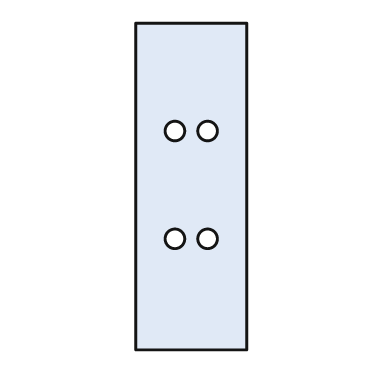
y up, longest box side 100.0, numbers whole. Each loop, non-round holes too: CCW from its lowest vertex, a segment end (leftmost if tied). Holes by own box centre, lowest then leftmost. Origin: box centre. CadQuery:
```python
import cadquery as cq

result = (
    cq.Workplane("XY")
    .moveTo(-17.0, -50.0)
    .lineTo(17.0, -50.0)
    .lineTo(17.0, 50.0)
    .lineTo(-17.0, 50.0)
    .close()
    .moveTo(-5.0, -16.0)
    .circle(3.0)
    .moveTo(5.0, -16.0)
    .circle(3.0)
    .moveTo(-5.0, 17.0)
    .circle(3.0)
    .moveTo(5.0, 17.0)
    .circle(3.0)
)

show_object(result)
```